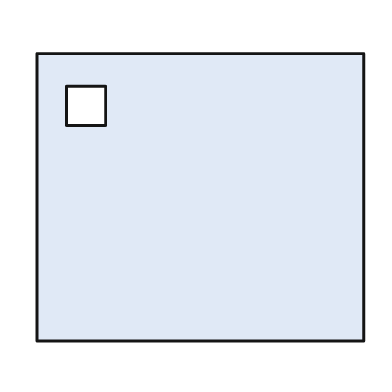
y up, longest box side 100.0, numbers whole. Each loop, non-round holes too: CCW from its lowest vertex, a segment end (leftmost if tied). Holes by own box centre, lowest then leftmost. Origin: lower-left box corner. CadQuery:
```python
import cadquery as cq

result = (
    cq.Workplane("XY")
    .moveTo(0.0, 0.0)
    .lineTo(100.0, 0.0)
    .lineTo(100.0, 88.0)
    .lineTo(0.0, 88.0)
    .close()
    .moveTo(9.0, 66.0)
    .lineTo(21.0, 66.0)
    .lineTo(21.0, 78.0)
    .lineTo(9.0, 78.0)
    .close()
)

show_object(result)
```